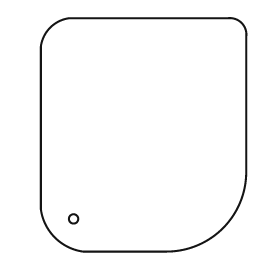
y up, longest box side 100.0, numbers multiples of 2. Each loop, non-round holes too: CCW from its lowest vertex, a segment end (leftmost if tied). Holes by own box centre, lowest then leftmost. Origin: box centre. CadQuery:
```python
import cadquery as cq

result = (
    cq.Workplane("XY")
    .moveTo(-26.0, -50.0)
    .lineTo(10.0, -50.0)
    .threePointArc((34.0, -40.0), (44.0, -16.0))
    .lineTo(44.0, 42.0)
    .threePointArc((42.0, 48.0), (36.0, 50.0))
    .lineTo(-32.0, 50.0)
    .threePointArc((-40.0, 46.0), (-44.0, 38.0))
    .lineTo(-44.0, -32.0)
    .threePointArc((-38.0, -44.0), (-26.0, -50.0))
    .close()
    .moveTo(-30.0, -36.0)
    .circle(2.0)
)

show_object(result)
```